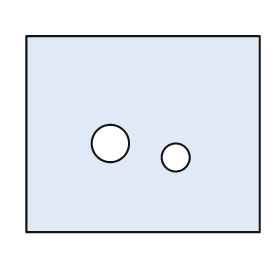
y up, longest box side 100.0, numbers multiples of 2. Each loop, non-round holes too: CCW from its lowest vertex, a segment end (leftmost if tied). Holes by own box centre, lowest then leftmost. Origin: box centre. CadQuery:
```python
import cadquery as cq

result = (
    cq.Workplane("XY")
    .moveTo(-50.0, -42.0)
    .lineTo(50.0, -42.0)
    .lineTo(50.0, 42.0)
    .lineTo(-50.0, 42.0)
    .close()
    .moveTo(14.0, -10.0)
    .circle(6.0)
    .moveTo(-14.0, -4.0)
    .circle(8.0)
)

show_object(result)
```